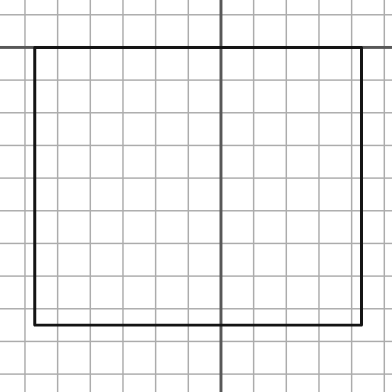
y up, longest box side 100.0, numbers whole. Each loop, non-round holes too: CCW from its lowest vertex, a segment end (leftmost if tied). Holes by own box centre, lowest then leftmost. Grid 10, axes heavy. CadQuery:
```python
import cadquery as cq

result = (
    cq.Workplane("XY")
    .moveTo(-57.0, -85.0)
    .lineTo(43.0, -85.0)
    .lineTo(43.0, 0.0)
    .lineTo(-57.0, 0.0)
    .close()
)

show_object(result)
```